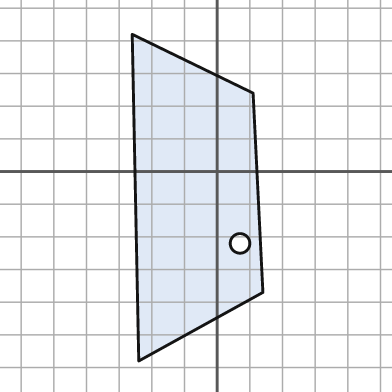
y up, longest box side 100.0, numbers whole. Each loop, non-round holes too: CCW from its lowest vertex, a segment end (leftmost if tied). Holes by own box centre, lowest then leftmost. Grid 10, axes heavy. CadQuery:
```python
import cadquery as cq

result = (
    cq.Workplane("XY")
    .moveTo(-24.0, -58.0)
    .lineTo(14.0, -37.0)
    .lineTo(11.0, 24.0)
    .lineTo(-26.0, 42.0)
    .close()
    .moveTo(7.0, -22.0)
    .circle(3.0)
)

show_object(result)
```